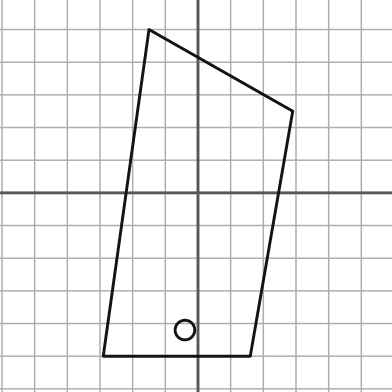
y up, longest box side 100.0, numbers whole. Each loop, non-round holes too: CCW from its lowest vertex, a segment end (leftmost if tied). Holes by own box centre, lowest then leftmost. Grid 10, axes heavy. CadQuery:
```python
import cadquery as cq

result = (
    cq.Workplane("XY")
    .moveTo(-29.0, -50.0)
    .lineTo(16.0, -50.0)
    .lineTo(29.0, 25.0)
    .lineTo(-15.0, 50.0)
    .close()
    .moveTo(-4.0, -42.0)
    .circle(3.0)
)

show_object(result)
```